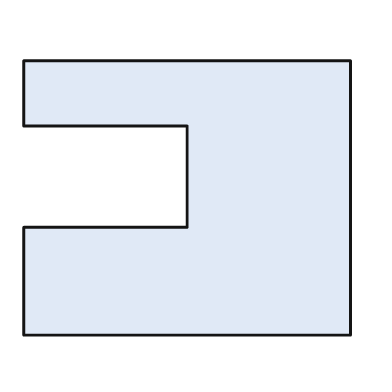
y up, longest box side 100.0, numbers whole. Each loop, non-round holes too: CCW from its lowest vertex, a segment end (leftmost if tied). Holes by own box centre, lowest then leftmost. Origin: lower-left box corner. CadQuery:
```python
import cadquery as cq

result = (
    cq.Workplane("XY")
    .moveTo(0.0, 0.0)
    .lineTo(100.0, 0.0)
    .lineTo(100.0, 84.0)
    .lineTo(0.0, 84.0)
    .lineTo(0.0, 64.0)
    .lineTo(50.0, 64.0)
    .lineTo(50.0, 33.0)
    .lineTo(0.0, 33.0)
    .close()
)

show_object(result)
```